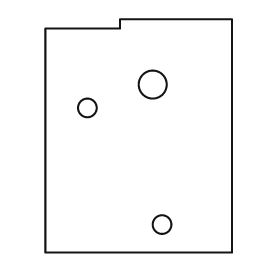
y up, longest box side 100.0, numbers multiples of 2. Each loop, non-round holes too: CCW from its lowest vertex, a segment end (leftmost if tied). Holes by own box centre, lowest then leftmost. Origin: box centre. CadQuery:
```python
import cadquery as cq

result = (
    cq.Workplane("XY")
    .moveTo(-40.0, -50.0)
    .lineTo(40.0, -50.0)
    .lineTo(40.0, 50.0)
    .lineTo(-8.0, 50.0)
    .lineTo(-8.0, 46.0)
    .lineTo(-40.0, 46.0)
    .close()
    .moveTo(10.0, -38.0)
    .circle(4.0)
    .moveTo(-22.0, 12.0)
    .circle(4.0)
    .moveTo(6.0, 22.0)
    .circle(6.0)
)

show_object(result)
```